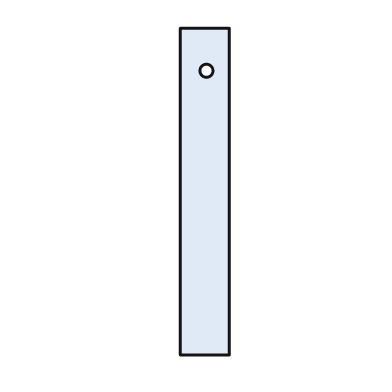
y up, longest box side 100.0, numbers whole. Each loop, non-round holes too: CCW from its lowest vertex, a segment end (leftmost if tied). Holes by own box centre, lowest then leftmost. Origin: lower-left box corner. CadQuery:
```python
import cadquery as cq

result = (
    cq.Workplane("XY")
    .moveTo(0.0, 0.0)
    .lineTo(15.0, 0.0)
    .lineTo(15.0, 100.0)
    .lineTo(0.0, 100.0)
    .close()
    .moveTo(8.0, 87.0)
    .circle(2.0)
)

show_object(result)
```